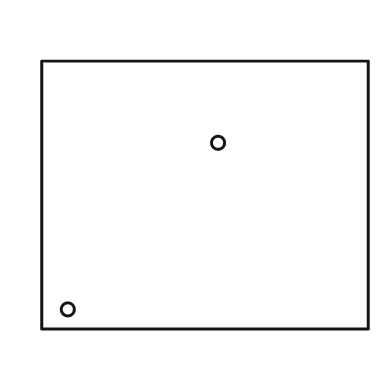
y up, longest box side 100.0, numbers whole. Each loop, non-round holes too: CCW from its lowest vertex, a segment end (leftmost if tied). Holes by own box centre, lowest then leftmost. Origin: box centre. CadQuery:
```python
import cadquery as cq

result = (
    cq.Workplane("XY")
    .moveTo(-50.0, -41.0)
    .lineTo(50.0, -41.0)
    .lineTo(50.0, 41.0)
    .lineTo(-50.0, 41.0)
    .close()
    .moveTo(-42.0, -35.0)
    .circle(2.0)
    .moveTo(4.0, 16.0)
    .circle(2.0)
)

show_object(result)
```